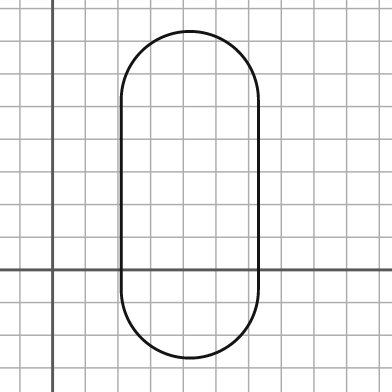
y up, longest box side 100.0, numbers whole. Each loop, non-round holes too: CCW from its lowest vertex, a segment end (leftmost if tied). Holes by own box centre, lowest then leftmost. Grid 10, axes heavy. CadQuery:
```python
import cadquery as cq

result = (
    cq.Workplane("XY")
    .moveTo(21.0, -6.0)
    .threePointArc((42.0, -27.0), (63.0, -6.0))
    .lineTo(63.0, 52.0)
    .threePointArc((42.0, 73.0), (21.0, 52.0))
    .close()
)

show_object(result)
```